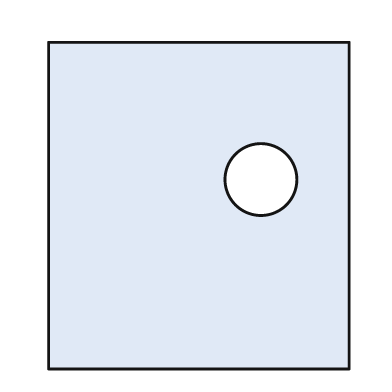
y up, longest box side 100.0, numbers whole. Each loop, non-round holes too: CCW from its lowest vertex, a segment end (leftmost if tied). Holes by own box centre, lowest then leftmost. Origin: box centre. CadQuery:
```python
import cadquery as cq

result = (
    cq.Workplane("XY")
    .moveTo(-46.0, -50.0)
    .lineTo(46.0, -50.0)
    .lineTo(46.0, 50.0)
    .lineTo(-46.0, 50.0)
    .close()
    .moveTo(19.0, 8.0)
    .circle(11.0)
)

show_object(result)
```